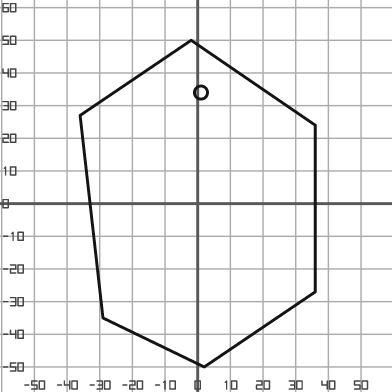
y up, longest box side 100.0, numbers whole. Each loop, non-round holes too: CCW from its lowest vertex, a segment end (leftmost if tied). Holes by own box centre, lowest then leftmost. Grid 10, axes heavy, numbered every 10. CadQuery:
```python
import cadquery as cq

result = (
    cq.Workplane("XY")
    .moveTo(2.0, -50.0)
    .lineTo(36.0, -27.0)
    .lineTo(36.0, 24.0)
    .lineTo(-2.0, 50.0)
    .lineTo(-36.0, 27.0)
    .lineTo(-29.0, -35.0)
    .close()
    .moveTo(1.0, 34.0)
    .circle(2.0)
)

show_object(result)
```